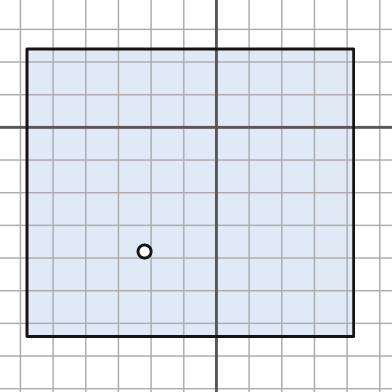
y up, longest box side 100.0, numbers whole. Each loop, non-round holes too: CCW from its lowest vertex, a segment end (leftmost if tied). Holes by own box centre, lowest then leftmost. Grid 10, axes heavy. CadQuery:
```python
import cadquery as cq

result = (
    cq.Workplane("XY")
    .moveTo(-58.0, -64.0)
    .lineTo(42.0, -64.0)
    .lineTo(42.0, 24.0)
    .lineTo(-58.0, 24.0)
    .close()
    .moveTo(-22.0, -38.0)
    .circle(2.0)
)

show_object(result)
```